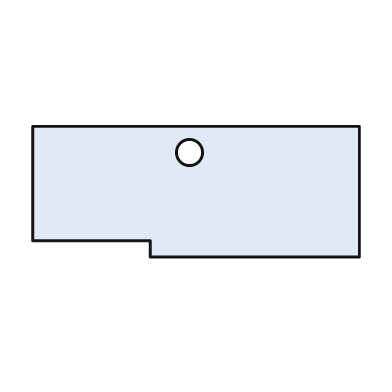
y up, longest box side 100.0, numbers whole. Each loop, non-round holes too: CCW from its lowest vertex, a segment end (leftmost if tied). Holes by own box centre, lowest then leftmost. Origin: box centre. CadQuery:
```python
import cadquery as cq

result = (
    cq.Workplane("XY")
    .moveTo(-14.0, -20.0)
    .lineTo(50.0, -20.0)
    .lineTo(50.0, 20.0)
    .lineTo(-50.0, 20.0)
    .lineTo(-50.0, -15.0)
    .lineTo(-14.0, -15.0)
    .close()
    .moveTo(-2.0, 12.0)
    .circle(4.0)
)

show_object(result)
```